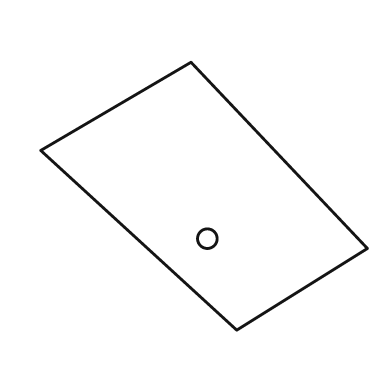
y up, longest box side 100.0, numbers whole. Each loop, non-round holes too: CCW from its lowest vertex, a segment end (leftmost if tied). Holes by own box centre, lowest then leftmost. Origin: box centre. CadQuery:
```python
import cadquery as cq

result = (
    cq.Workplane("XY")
    .moveTo(10.0, -41.0)
    .lineTo(50.0, -16.0)
    .lineTo(-4.0, 41.0)
    .lineTo(-50.0, 14.0)
    .close()
    .moveTo(1.0, -13.0)
    .circle(3.0)
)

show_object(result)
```